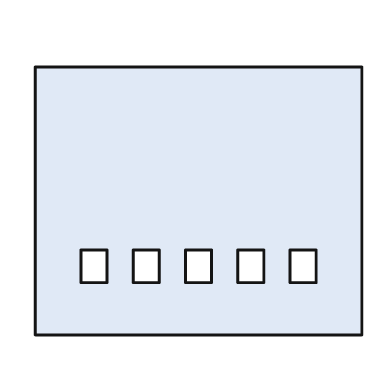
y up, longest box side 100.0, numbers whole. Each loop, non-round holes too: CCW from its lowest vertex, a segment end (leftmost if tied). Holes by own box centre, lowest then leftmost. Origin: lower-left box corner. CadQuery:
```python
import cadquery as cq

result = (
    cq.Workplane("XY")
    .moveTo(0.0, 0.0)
    .lineTo(100.0, 0.0)
    .lineTo(100.0, 82.0)
    .lineTo(0.0, 82.0)
    .close()
    .moveTo(14.0, 16.0)
    .lineTo(22.0, 16.0)
    .lineTo(22.0, 26.0)
    .lineTo(14.0, 26.0)
    .close()
    .moveTo(30.0, 16.0)
    .lineTo(38.0, 16.0)
    .lineTo(38.0, 26.0)
    .lineTo(30.0, 26.0)
    .close()
    .moveTo(46.0, 16.0)
    .lineTo(54.0, 16.0)
    .lineTo(54.0, 26.0)
    .lineTo(46.0, 26.0)
    .close()
    .moveTo(62.0, 16.0)
    .lineTo(70.0, 16.0)
    .lineTo(70.0, 26.0)
    .lineTo(62.0, 26.0)
    .close()
    .moveTo(78.0, 16.0)
    .lineTo(86.0, 16.0)
    .lineTo(86.0, 26.0)
    .lineTo(78.0, 26.0)
    .close()
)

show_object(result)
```